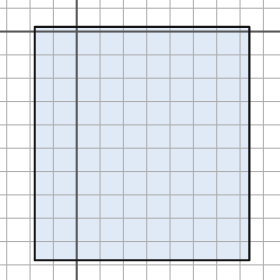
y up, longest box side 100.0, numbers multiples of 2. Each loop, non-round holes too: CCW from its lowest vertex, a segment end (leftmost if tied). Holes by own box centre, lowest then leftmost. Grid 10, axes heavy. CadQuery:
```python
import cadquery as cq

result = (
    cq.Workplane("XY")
    .moveTo(-18.0, -98.0)
    .lineTo(74.0, -98.0)
    .lineTo(74.0, 2.0)
    .lineTo(-18.0, 2.0)
    .close()
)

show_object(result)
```